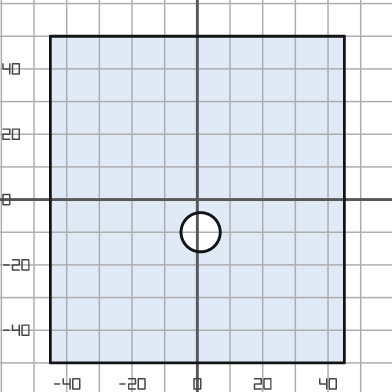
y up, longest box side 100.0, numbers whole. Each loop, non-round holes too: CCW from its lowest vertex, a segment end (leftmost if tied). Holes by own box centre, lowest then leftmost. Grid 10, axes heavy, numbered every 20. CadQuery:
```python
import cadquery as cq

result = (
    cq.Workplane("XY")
    .moveTo(-45.0, -50.0)
    .lineTo(45.0, -50.0)
    .lineTo(45.0, 50.0)
    .lineTo(-45.0, 50.0)
    .close()
    .moveTo(1.0, -10.0)
    .circle(6.0)
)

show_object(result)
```